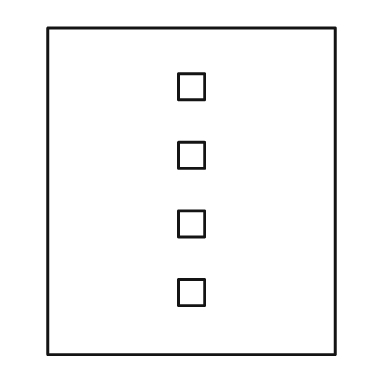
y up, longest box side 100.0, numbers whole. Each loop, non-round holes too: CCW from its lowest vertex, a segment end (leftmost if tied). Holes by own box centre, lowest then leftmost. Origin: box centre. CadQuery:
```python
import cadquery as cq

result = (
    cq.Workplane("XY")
    .moveTo(-44.0, -50.0)
    .lineTo(44.0, -50.0)
    .lineTo(44.0, 50.0)
    .lineTo(-44.0, 50.0)
    .close()
    .moveTo(-4.0, -35.0)
    .lineTo(4.0, -35.0)
    .lineTo(4.0, -27.0)
    .lineTo(-4.0, -27.0)
    .close()
    .moveTo(-4.0, -14.0)
    .lineTo(4.0, -14.0)
    .lineTo(4.0, -6.0)
    .lineTo(-4.0, -6.0)
    .close()
    .moveTo(-4.0, 7.0)
    .lineTo(4.0, 7.0)
    .lineTo(4.0, 15.0)
    .lineTo(-4.0, 15.0)
    .close()
    .moveTo(-4.0, 28.0)
    .lineTo(4.0, 28.0)
    .lineTo(4.0, 36.0)
    .lineTo(-4.0, 36.0)
    .close()
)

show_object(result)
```